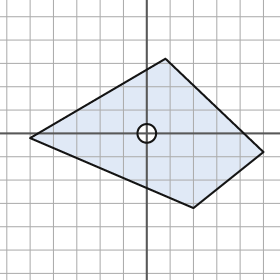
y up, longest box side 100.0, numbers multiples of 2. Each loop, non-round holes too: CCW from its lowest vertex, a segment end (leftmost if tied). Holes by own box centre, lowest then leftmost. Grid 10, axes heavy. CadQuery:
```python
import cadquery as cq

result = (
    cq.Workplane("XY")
    .moveTo(20.0, -32.0)
    .lineTo(50.0, -8.0)
    .lineTo(8.0, 32.0)
    .lineTo(-50.0, -2.0)
    .close()
    .moveTo(0.0, 0.0)
    .circle(4.0)
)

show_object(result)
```